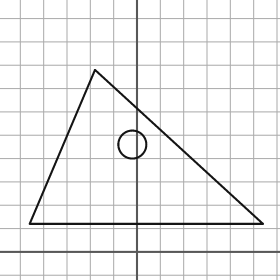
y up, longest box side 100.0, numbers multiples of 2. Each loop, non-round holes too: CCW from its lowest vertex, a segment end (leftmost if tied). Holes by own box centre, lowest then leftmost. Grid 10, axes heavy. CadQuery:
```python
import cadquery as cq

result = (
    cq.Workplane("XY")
    .moveTo(-46.0, 12.0)
    .lineTo(54.0, 12.0)
    .lineTo(-18.0, 78.0)
    .close()
    .moveTo(-2.0, 46.0)
    .circle(6.0)
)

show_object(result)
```